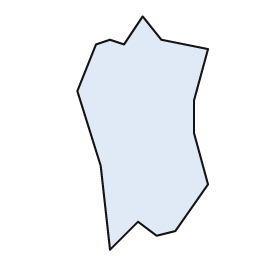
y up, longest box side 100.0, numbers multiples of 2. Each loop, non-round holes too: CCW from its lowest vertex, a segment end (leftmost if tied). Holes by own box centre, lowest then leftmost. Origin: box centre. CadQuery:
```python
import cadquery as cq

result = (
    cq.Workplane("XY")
    .moveTo(-14.0, -50.0)
    .lineTo(-2.0, -38.0)
    .lineTo(6.0, -44.0)
    .lineTo(14.0, -42.0)
    .lineTo(28.0, -22.0)
    .lineTo(22.0, 0.0)
    .lineTo(22.0, 14.0)
    .lineTo(28.0, 36.0)
    .lineTo(8.0, 40.0)
    .lineTo(0.0, 50.0)
    .lineTo(-8.0, 38.0)
    .lineTo(-14.0, 40.0)
    .lineTo(-20.0, 38.0)
    .lineTo(-28.0, 18.0)
    .lineTo(-18.0, -14.0)
    .close()
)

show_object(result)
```